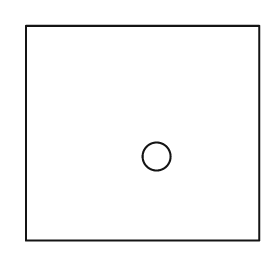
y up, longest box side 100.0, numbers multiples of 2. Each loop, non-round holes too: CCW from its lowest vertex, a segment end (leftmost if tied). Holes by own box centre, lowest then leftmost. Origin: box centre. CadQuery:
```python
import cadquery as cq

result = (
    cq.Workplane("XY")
    .moveTo(-50.0, -46.0)
    .lineTo(50.0, -46.0)
    .lineTo(50.0, 46.0)
    .lineTo(-50.0, 46.0)
    .close()
    .moveTo(6.0, -10.0)
    .circle(6.0)
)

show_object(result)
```